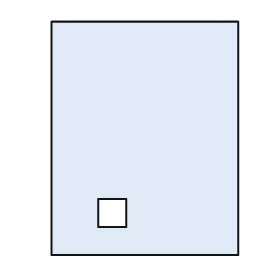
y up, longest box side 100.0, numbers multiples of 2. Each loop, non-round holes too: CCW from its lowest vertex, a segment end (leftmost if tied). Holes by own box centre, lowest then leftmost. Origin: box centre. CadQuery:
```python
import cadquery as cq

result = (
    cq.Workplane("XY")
    .moveTo(-40.0, -50.0)
    .lineTo(40.0, -50.0)
    .lineTo(40.0, 50.0)
    .lineTo(-40.0, 50.0)
    .close()
    .moveTo(-20.0, -38.0)
    .lineTo(-8.0, -38.0)
    .lineTo(-8.0, -26.0)
    .lineTo(-20.0, -26.0)
    .close()
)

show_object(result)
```